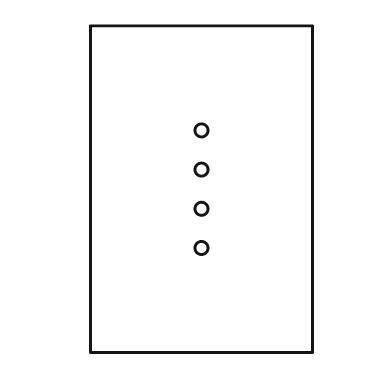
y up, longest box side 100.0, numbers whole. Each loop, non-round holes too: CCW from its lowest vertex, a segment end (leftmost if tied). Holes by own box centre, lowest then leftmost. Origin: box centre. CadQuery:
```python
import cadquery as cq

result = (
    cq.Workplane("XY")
    .moveTo(-34.0, -50.0)
    .lineTo(34.0, -50.0)
    .lineTo(34.0, 50.0)
    .lineTo(-34.0, 50.0)
    .close()
    .moveTo(0.0, -18.0)
    .circle(2.0)
    .moveTo(0.0, -6.0)
    .circle(2.0)
    .moveTo(0.0, 6.0)
    .circle(2.0)
    .moveTo(0.0, 18.0)
    .circle(2.0)
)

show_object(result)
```